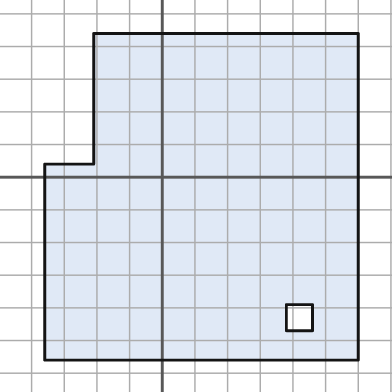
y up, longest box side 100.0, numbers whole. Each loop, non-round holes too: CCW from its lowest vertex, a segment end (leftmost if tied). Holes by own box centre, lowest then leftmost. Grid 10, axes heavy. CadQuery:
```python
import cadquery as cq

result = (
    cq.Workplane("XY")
    .moveTo(-36.0, -56.0)
    .lineTo(60.0, -56.0)
    .lineTo(60.0, 44.0)
    .lineTo(-21.0, 44.0)
    .lineTo(-21.0, 4.0)
    .lineTo(-36.0, 4.0)
    .close()
    .moveTo(38.0, -47.0)
    .lineTo(46.0, -47.0)
    .lineTo(46.0, -39.0)
    .lineTo(38.0, -39.0)
    .close()
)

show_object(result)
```